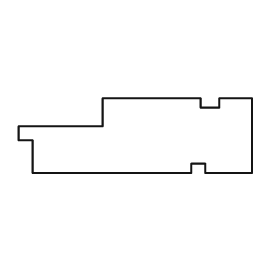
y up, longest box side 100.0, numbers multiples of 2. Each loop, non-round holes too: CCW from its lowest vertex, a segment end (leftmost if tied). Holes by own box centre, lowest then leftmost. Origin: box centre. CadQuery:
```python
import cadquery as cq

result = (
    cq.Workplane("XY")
    .moveTo(-44.0, -16.0)
    .lineTo(24.0, -16.0)
    .lineTo(24.0, -12.0)
    .lineTo(30.0, -12.0)
    .lineTo(30.0, -16.0)
    .lineTo(50.0, -16.0)
    .lineTo(50.0, 16.0)
    .lineTo(36.0, 16.0)
    .lineTo(36.0, 12.0)
    .lineTo(28.0, 12.0)
    .lineTo(28.0, 16.0)
    .lineTo(-14.0, 16.0)
    .lineTo(-14.0, 4.0)
    .lineTo(-50.0, 4.0)
    .lineTo(-50.0, -2.0)
    .lineTo(-44.0, -2.0)
    .close()
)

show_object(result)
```